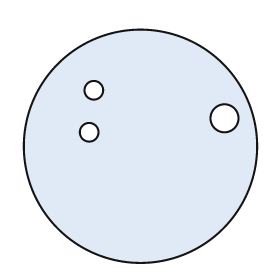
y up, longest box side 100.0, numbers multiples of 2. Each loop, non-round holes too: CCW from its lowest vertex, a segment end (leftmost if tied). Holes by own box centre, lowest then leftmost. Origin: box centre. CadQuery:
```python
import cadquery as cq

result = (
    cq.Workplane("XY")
    .moveTo(0.0, 0.0)
    .circle(50.0)
    .moveTo(-22.0, 6.0)
    .circle(4.0)
    .moveTo(36.0, 12.0)
    .circle(6.0)
    .moveTo(-20.0, 24.0)
    .circle(4.0)
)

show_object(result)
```